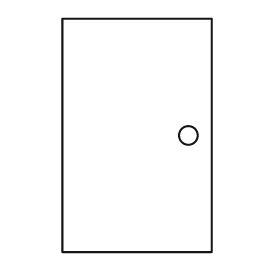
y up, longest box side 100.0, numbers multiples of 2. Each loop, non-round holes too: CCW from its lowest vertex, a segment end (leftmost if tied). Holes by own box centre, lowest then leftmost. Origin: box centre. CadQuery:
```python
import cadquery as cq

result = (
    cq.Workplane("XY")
    .moveTo(-32.0, -50.0)
    .lineTo(32.0, -50.0)
    .lineTo(32.0, 50.0)
    .lineTo(-32.0, 50.0)
    .close()
    .moveTo(22.0, 0.0)
    .circle(4.0)
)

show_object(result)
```